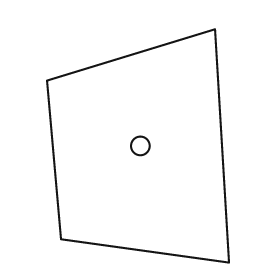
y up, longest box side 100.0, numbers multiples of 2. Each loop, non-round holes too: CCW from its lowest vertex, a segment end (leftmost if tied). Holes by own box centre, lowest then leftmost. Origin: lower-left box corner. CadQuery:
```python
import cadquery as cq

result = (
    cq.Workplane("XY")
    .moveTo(78.0, 0.0)
    .lineTo(72.0, 100.0)
    .lineTo(0.0, 78.0)
    .lineTo(6.0, 10.0)
    .close()
    .moveTo(40.0, 50.0)
    .circle(4.0)
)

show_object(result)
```